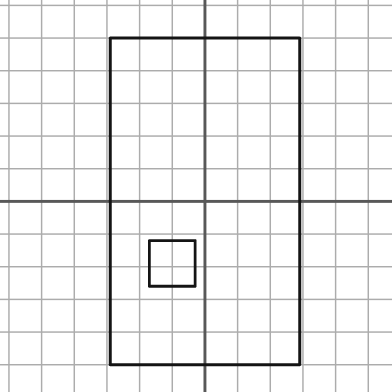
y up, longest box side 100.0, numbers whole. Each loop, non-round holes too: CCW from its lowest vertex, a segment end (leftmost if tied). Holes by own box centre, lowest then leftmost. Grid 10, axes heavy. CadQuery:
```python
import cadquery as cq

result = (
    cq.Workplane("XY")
    .moveTo(-29.0, -50.0)
    .lineTo(29.0, -50.0)
    .lineTo(29.0, 50.0)
    .lineTo(-29.0, 50.0)
    .close()
    .moveTo(-17.0, -26.0)
    .lineTo(-3.0, -26.0)
    .lineTo(-3.0, -12.0)
    .lineTo(-17.0, -12.0)
    .close()
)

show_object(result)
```